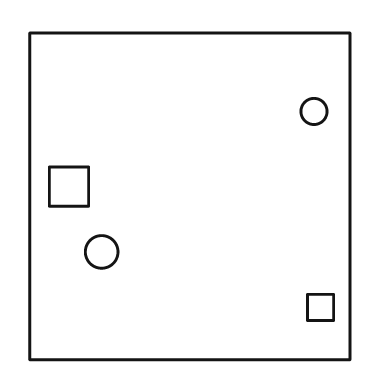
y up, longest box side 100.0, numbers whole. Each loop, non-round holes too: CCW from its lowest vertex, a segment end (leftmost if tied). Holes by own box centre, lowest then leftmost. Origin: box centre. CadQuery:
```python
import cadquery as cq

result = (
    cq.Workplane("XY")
    .moveTo(-49.0, -50.0)
    .lineTo(49.0, -50.0)
    .lineTo(49.0, 50.0)
    .lineTo(-49.0, 50.0)
    .close()
    .moveTo(36.0, -38.0)
    .lineTo(44.0, -38.0)
    .lineTo(44.0, -30.0)
    .lineTo(36.0, -30.0)
    .close()
    .moveTo(-27.0, -17.0)
    .circle(5.0)
    .moveTo(-43.0, -3.0)
    .lineTo(-31.0, -3.0)
    .lineTo(-31.0, 9.0)
    .lineTo(-43.0, 9.0)
    .close()
    .moveTo(38.0, 26.0)
    .circle(4.0)
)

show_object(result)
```